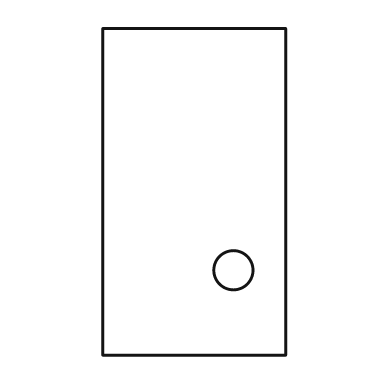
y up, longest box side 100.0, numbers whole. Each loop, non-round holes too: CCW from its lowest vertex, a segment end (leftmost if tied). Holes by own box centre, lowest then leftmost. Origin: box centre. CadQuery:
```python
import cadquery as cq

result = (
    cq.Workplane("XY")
    .moveTo(-28.0, -50.0)
    .lineTo(28.0, -50.0)
    .lineTo(28.0, 50.0)
    .lineTo(-28.0, 50.0)
    .close()
    .moveTo(12.0, -24.0)
    .circle(6.0)
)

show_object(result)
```